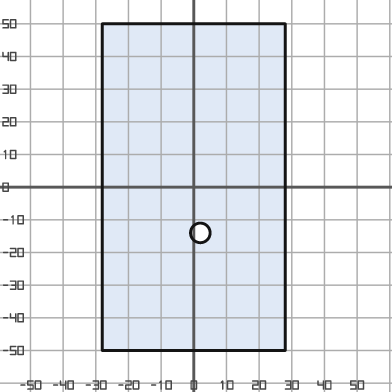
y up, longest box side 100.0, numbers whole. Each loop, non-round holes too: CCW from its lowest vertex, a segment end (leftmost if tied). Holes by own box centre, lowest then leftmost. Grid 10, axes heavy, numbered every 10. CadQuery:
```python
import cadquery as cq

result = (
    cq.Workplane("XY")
    .moveTo(-28.0, -50.0)
    .lineTo(28.0, -50.0)
    .lineTo(28.0, 50.0)
    .lineTo(-28.0, 50.0)
    .close()
    .moveTo(2.0, -14.0)
    .circle(3.0)
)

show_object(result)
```